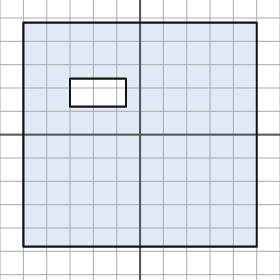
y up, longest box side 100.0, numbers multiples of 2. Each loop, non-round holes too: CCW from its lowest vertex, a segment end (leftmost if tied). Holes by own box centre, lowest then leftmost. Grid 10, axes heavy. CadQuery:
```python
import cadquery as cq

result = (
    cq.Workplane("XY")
    .moveTo(-50.0, -48.0)
    .lineTo(50.0, -48.0)
    .lineTo(50.0, 48.0)
    .lineTo(-50.0, 48.0)
    .close()
    .moveTo(-30.0, 12.0)
    .lineTo(-6.0, 12.0)
    .lineTo(-6.0, 24.0)
    .lineTo(-30.0, 24.0)
    .close()
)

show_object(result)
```